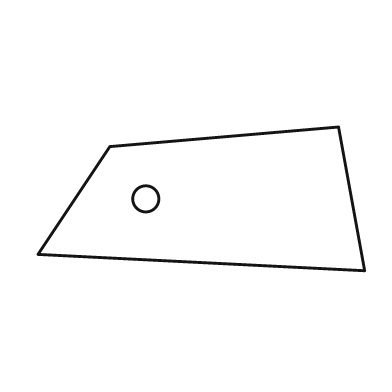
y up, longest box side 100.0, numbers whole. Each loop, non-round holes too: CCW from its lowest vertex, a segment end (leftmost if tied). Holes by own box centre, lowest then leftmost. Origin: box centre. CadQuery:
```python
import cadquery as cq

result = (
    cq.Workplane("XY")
    .moveTo(50.0, -22.0)
    .lineTo(42.0, 22.0)
    .lineTo(-28.0, 16.0)
    .lineTo(-50.0, -17.0)
    .close()
    .moveTo(-17.0, 0.0)
    .circle(4.0)
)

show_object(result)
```